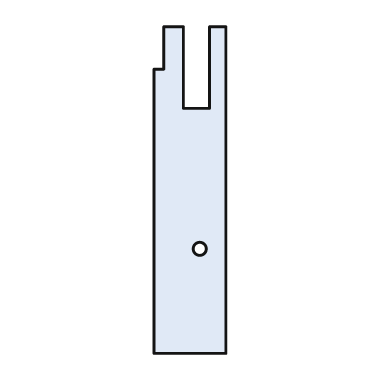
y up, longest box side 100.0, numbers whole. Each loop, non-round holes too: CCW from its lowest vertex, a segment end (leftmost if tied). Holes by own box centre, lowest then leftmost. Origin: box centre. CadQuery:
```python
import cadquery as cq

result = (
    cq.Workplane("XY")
    .moveTo(-11.0, -50.0)
    .lineTo(11.0, -50.0)
    .lineTo(11.0, 50.0)
    .lineTo(6.0, 50.0)
    .lineTo(6.0, 25.0)
    .lineTo(-2.0, 25.0)
    .lineTo(-2.0, 50.0)
    .lineTo(-8.0, 50.0)
    .lineTo(-8.0, 37.0)
    .lineTo(-11.0, 37.0)
    .close()
    .moveTo(3.0, -18.0)
    .circle(2.0)
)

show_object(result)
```